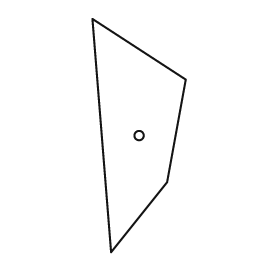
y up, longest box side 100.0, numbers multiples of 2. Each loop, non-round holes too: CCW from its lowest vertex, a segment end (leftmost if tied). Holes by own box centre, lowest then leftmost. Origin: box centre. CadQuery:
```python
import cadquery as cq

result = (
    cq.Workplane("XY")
    .moveTo(-12.0, -50.0)
    .lineTo(12.0, -20.0)
    .lineTo(20.0, 24.0)
    .lineTo(-20.0, 50.0)
    .close()
    .moveTo(0.0, 0.0)
    .circle(2.0)
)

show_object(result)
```